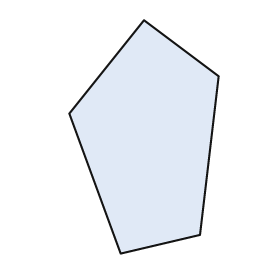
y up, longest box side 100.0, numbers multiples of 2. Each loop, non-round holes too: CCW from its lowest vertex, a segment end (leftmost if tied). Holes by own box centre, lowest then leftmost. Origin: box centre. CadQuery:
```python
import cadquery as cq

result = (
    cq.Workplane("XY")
    .moveTo(-10.0, -50.0)
    .lineTo(24.0, -42.0)
    .lineTo(32.0, 26.0)
    .lineTo(0.0, 50.0)
    .lineTo(-32.0, 10.0)
    .close()
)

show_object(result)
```